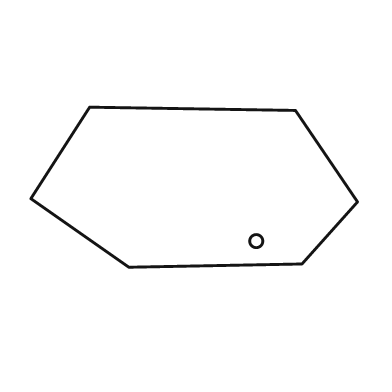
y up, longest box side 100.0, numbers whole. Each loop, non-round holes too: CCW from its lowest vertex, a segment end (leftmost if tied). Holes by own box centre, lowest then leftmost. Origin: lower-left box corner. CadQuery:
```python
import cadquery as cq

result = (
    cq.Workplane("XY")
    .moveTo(30.0, 0.0)
    .lineTo(83.0, 1.0)
    .lineTo(100.0, 20.0)
    .lineTo(81.0, 48.0)
    .lineTo(18.0, 49.0)
    .lineTo(0.0, 21.0)
    .close()
    .moveTo(69.0, 8.0)
    .circle(2.0)
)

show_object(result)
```